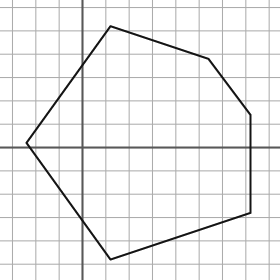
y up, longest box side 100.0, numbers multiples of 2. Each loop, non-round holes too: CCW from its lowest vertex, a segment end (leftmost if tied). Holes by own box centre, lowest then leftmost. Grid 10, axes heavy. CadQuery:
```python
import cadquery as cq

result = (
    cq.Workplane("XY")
    .moveTo(12.0, -48.0)
    .lineTo(72.0, -28.0)
    .lineTo(72.0, 14.0)
    .lineTo(54.0, 38.0)
    .lineTo(12.0, 52.0)
    .lineTo(-24.0, 2.0)
    .close()
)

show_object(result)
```